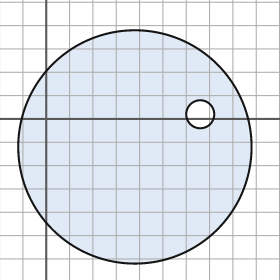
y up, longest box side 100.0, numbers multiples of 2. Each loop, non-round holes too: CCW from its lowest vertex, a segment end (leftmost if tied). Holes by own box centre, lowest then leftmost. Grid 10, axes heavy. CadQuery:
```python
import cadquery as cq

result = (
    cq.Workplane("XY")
    .moveTo(38.0, -12.0)
    .circle(50.0)
    .moveTo(66.0, 2.0)
    .circle(6.0)
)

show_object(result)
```